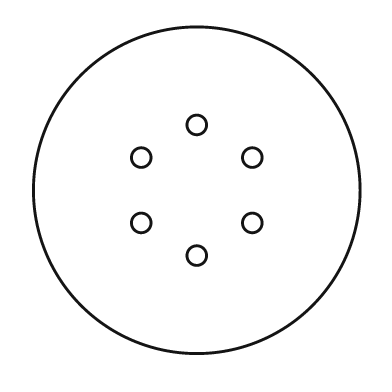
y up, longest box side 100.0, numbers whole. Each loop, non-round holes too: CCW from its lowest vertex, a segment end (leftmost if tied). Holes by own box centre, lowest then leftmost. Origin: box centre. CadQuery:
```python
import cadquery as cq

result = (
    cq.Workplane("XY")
    .moveTo(0.0, 0.0)
    .circle(50.0)
    .moveTo(0.0, -20.0)
    .circle(3.0)
    .moveTo(-17.0, -10.0)
    .circle(3.0)
    .moveTo(17.0, -10.0)
    .circle(3.0)
    .moveTo(-17.0, 10.0)
    .circle(3.0)
    .moveTo(17.0, 10.0)
    .circle(3.0)
    .moveTo(0.0, 20.0)
    .circle(3.0)
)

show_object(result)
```